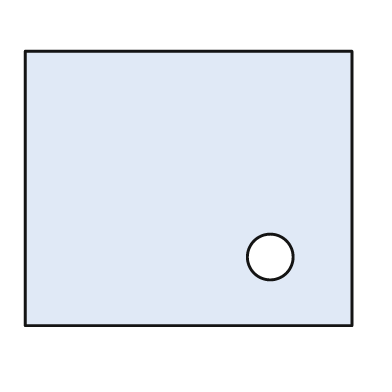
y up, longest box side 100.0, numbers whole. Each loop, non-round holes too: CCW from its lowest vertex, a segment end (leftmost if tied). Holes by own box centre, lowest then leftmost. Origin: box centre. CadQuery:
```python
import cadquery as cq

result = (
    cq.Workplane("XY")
    .moveTo(-50.0, -42.0)
    .lineTo(50.0, -42.0)
    .lineTo(50.0, 42.0)
    .lineTo(-50.0, 42.0)
    .close()
    .moveTo(25.0, -21.0)
    .circle(7.0)
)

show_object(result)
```